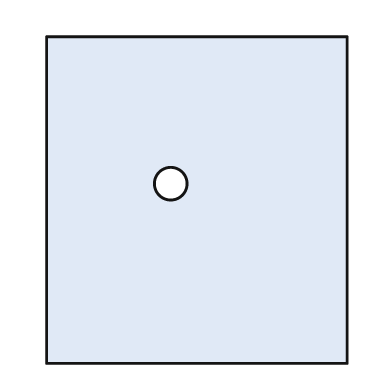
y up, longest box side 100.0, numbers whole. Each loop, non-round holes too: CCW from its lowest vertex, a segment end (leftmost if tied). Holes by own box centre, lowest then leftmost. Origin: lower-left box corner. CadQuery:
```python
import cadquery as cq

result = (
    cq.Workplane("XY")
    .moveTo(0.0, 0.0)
    .lineTo(92.0, 0.0)
    .lineTo(92.0, 100.0)
    .lineTo(0.0, 100.0)
    .close()
    .moveTo(38.0, 55.0)
    .circle(5.0)
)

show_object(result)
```